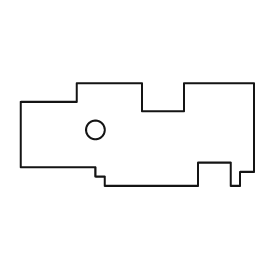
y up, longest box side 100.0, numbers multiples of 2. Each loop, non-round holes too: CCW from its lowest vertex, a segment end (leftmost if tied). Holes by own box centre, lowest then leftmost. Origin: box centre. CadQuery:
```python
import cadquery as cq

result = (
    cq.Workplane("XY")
    .moveTo(-14.0, -22.0)
    .lineTo(26.0, -22.0)
    .lineTo(26.0, -12.0)
    .lineTo(40.0, -12.0)
    .lineTo(40.0, -22.0)
    .lineTo(44.0, -22.0)
    .lineTo(44.0, -16.0)
    .lineTo(50.0, -16.0)
    .lineTo(50.0, 22.0)
    .lineTo(20.0, 22.0)
    .lineTo(20.0, 10.0)
    .lineTo(2.0, 10.0)
    .lineTo(2.0, 22.0)
    .lineTo(-26.0, 22.0)
    .lineTo(-26.0, 14.0)
    .lineTo(-50.0, 14.0)
    .lineTo(-50.0, -14.0)
    .lineTo(-18.0, -14.0)
    .lineTo(-18.0, -18.0)
    .lineTo(-14.0, -18.0)
    .close()
    .moveTo(-18.0, 2.0)
    .circle(4.0)
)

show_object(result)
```